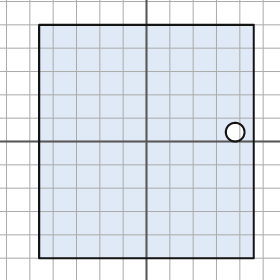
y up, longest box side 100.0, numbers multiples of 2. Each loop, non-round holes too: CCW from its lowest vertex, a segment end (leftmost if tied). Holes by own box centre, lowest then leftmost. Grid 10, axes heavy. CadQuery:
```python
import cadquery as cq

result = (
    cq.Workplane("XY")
    .moveTo(-46.0, -50.0)
    .lineTo(46.0, -50.0)
    .lineTo(46.0, 50.0)
    .lineTo(-46.0, 50.0)
    .close()
    .moveTo(38.0, 4.0)
    .circle(4.0)
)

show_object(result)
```